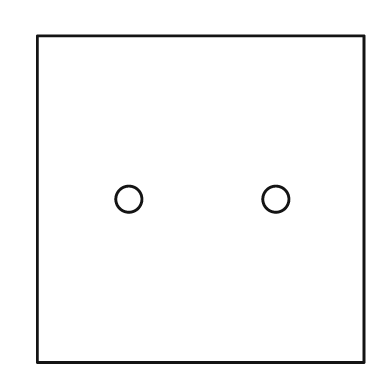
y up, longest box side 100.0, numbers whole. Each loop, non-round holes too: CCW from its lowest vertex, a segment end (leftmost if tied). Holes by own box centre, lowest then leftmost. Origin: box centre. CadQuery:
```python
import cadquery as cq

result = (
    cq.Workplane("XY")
    .moveTo(-50.0, -50.0)
    .lineTo(50.0, -50.0)
    .lineTo(50.0, 50.0)
    .lineTo(-50.0, 50.0)
    .close()
    .moveTo(-22.0, 0.0)
    .circle(4.0)
    .moveTo(23.0, 0.0)
    .circle(4.0)
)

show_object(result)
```